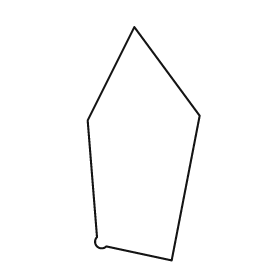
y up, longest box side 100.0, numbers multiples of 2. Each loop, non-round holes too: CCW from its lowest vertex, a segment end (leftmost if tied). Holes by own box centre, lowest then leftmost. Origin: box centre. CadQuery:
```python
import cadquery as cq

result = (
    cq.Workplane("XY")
    .moveTo(12.0, -50.0)
    .lineTo(24.0, 12.0)
    .lineTo(-4.0, 50.0)
    .lineTo(-24.0, 10.0)
    .lineTo(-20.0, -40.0)
    .threePointArc((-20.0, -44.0), (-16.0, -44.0))
    .close()
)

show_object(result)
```